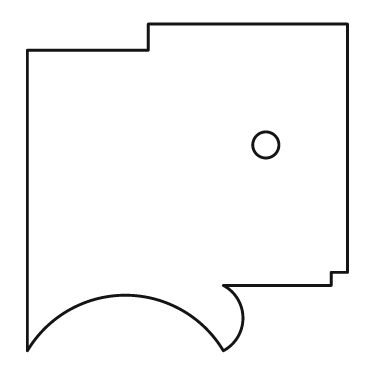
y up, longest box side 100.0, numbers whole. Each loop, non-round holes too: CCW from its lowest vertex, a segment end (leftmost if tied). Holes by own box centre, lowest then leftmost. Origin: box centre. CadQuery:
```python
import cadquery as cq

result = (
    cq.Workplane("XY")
    .moveTo(-49.0, -50.0)
    .threePointArc((-19.0, -33.0), (11.0, -50.0))
    .threePointArc((17.0, -40.0), (11.0, -30.0))
    .lineTo(44.0, -30.0)
    .lineTo(44.0, -26.0)
    .lineTo(49.0, -26.0)
    .lineTo(49.0, 50.0)
    .lineTo(-12.0, 50.0)
    .lineTo(-12.0, 42.0)
    .lineTo(-49.0, 42.0)
    .close()
    .moveTo(24.0, 13.0)
    .circle(4.0)
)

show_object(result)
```